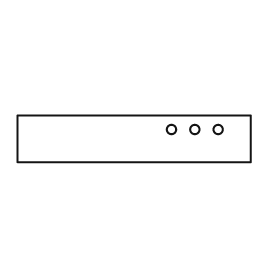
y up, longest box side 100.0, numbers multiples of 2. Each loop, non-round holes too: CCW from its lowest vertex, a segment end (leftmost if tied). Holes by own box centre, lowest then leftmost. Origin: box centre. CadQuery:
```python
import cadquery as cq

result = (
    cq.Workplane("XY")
    .moveTo(-50.0, -10.0)
    .lineTo(50.0, -10.0)
    .lineTo(50.0, 10.0)
    .lineTo(-50.0, 10.0)
    .close()
    .moveTo(16.0, 4.0)
    .circle(2.0)
    .moveTo(26.0, 4.0)
    .circle(2.0)
    .moveTo(36.0, 4.0)
    .circle(2.0)
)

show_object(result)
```